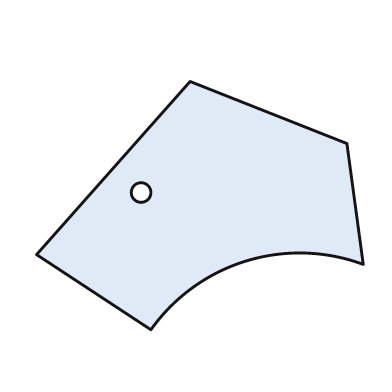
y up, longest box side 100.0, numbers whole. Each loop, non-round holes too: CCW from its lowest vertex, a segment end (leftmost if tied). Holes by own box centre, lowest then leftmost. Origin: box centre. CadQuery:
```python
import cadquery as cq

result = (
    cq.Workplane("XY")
    .moveTo(-15.0, -38.0)
    .threePointArc((14.0, -17.0), (50.0, -18.0))
    .lineTo(45.0, 19.0)
    .lineTo(-3.0, 38.0)
    .lineTo(-50.0, -15.0)
    .close()
    .moveTo(-18.0, 4.0)
    .circle(3.0)
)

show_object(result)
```